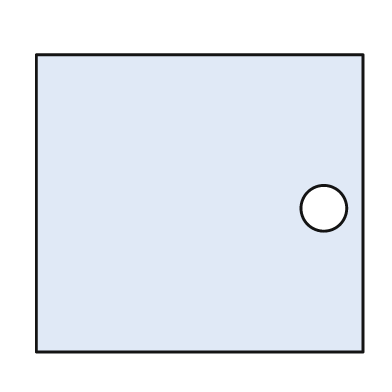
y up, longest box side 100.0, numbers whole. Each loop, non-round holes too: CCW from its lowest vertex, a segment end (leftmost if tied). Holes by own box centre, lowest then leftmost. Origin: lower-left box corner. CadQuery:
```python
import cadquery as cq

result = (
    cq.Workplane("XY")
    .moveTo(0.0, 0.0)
    .lineTo(100.0, 0.0)
    .lineTo(100.0, 91.0)
    .lineTo(0.0, 91.0)
    .close()
    .moveTo(88.0, 44.0)
    .circle(7.0)
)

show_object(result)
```